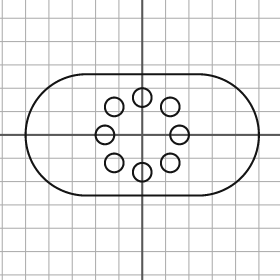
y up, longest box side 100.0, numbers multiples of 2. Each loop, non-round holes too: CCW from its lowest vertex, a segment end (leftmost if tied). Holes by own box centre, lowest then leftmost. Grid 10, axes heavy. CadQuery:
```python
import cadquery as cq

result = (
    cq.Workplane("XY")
    .moveTo(-24.0, -26.0)
    .lineTo(24.0, -26.0)
    .threePointArc((50.0, 0.0), (24.0, 26.0))
    .lineTo(-24.0, 26.0)
    .threePointArc((-50.0, 0.0), (-24.0, -26.0))
    .close()
    .moveTo(0.0, -16.0)
    .circle(4.0)
    .moveTo(-12.0, -12.0)
    .circle(4.0)
    .moveTo(12.0, -12.0)
    .circle(4.0)
    .moveTo(-16.0, 0.0)
    .circle(4.0)
    .moveTo(16.0, 0.0)
    .circle(4.0)
    .moveTo(-12.0, 12.0)
    .circle(4.0)
    .moveTo(12.0, 12.0)
    .circle(4.0)
    .moveTo(0.0, 16.0)
    .circle(4.0)
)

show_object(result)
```